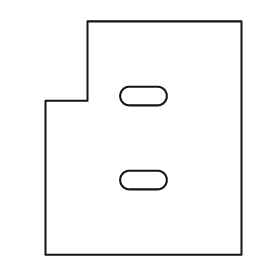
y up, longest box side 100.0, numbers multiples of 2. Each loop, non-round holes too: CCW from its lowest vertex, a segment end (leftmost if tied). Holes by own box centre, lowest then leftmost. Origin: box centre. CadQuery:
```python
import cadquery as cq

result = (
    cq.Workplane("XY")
    .moveTo(-42.0, -50.0)
    .lineTo(42.0, -50.0)
    .lineTo(42.0, 50.0)
    .lineTo(-24.0, 50.0)
    .lineTo(-24.0, 16.0)
    .lineTo(-42.0, 16.0)
    .close()
    .moveTo(-6.0, -22.0)
    .lineTo(6.0, -22.0)
    .threePointArc((10.0, -18.0), (6.0, -14.0))
    .lineTo(-6.0, -14.0)
    .threePointArc((-10.0, -18.0), (-6.0, -22.0))
    .close()
    .moveTo(-6.0, 14.0)
    .lineTo(6.0, 14.0)
    .threePointArc((10.0, 18.0), (6.0, 22.0))
    .lineTo(-6.0, 22.0)
    .threePointArc((-10.0, 18.0), (-6.0, 14.0))
    .close()
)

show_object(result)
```